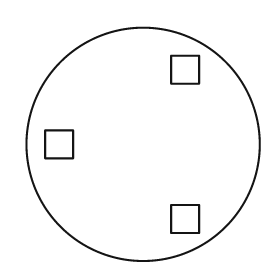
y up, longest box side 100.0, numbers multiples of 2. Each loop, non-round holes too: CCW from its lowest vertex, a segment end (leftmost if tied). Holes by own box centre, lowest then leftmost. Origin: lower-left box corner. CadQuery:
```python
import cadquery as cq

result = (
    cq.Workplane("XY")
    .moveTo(50.0, 50.0)
    .circle(50.0)
    .moveTo(62.0, 12.0)
    .lineTo(74.0, 12.0)
    .lineTo(74.0, 24.0)
    .lineTo(62.0, 24.0)
    .close()
    .moveTo(8.0, 44.0)
    .lineTo(20.0, 44.0)
    .lineTo(20.0, 56.0)
    .lineTo(8.0, 56.0)
    .close()
    .moveTo(62.0, 76.0)
    .lineTo(74.0, 76.0)
    .lineTo(74.0, 88.0)
    .lineTo(62.0, 88.0)
    .close()
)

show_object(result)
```